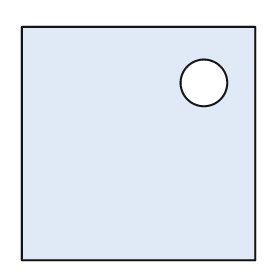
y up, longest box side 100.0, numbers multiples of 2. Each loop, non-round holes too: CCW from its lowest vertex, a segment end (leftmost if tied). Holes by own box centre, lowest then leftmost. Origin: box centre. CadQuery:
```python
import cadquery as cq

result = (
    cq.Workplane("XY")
    .moveTo(-50.0, -50.0)
    .lineTo(50.0, -50.0)
    .lineTo(50.0, 50.0)
    .lineTo(-50.0, 50.0)
    .close()
    .moveTo(28.0, 26.0)
    .circle(10.0)
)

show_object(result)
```